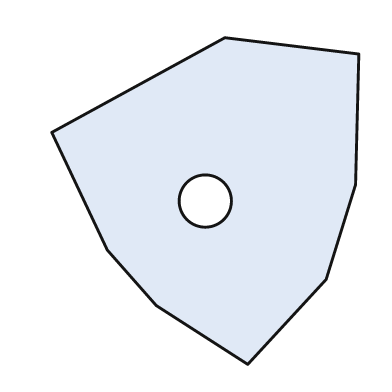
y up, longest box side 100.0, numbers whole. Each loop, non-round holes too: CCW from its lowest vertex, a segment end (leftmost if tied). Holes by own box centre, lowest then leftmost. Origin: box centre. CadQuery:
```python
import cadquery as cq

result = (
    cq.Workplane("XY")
    .moveTo(13.0, -50.0)
    .lineTo(37.0, -24.0)
    .lineTo(46.0, 5.0)
    .lineTo(47.0, 45.0)
    .lineTo(6.0, 50.0)
    .lineTo(-47.0, 21.0)
    .lineTo(-30.0, -15.0)
    .lineTo(-15.0, -32.0)
    .close()
    .moveTo(0.0, 0.0)
    .circle(8.0)
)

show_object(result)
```